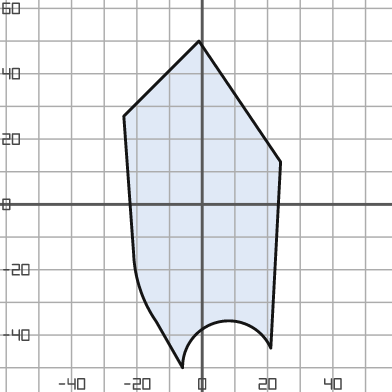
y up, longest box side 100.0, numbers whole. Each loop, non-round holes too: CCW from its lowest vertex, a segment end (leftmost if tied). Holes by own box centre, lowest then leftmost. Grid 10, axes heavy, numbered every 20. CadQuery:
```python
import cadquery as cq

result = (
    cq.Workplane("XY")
    .moveTo(-6.0, -50.0)
    .threePointArc((5.0, -36.0), (21.0, -44.0))
    .lineTo(24.0, 13.0)
    .lineTo(-1.0, 50.0)
    .lineTo(-24.0, 27.0)
    .lineTo(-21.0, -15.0)
    .threePointArc((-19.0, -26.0), (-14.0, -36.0))
    .close()
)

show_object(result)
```